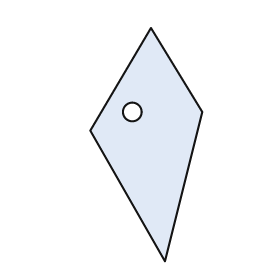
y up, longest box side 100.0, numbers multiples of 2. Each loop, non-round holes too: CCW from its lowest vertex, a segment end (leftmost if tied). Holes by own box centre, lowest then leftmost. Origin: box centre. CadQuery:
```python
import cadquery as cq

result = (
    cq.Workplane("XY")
    .moveTo(8.0, -50.0)
    .lineTo(24.0, 14.0)
    .lineTo(2.0, 50.0)
    .lineTo(-24.0, 6.0)
    .close()
    .moveTo(-6.0, 14.0)
    .circle(4.0)
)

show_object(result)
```